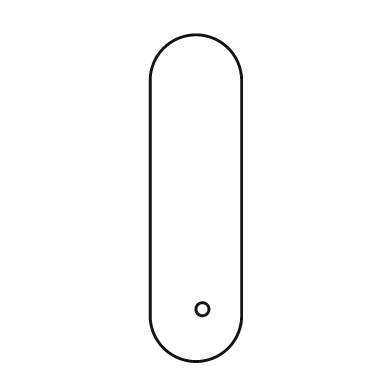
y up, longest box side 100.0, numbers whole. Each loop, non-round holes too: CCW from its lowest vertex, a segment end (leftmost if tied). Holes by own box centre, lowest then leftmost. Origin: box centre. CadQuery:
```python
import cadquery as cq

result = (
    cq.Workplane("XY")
    .moveTo(-14.0, -36.0)
    .threePointArc((0.0, -50.0), (14.0, -36.0))
    .lineTo(14.0, 36.0)
    .threePointArc((0.0, 50.0), (-14.0, 36.0))
    .close()
    .moveTo(2.0, -34.0)
    .circle(2.0)
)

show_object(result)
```